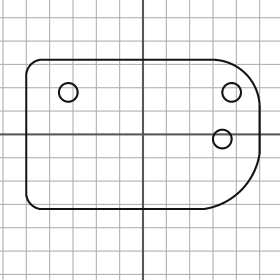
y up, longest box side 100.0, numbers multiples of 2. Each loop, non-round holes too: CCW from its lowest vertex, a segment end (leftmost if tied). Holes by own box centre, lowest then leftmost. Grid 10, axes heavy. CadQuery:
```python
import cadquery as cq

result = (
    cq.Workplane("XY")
    .moveTo(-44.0, -32.0)
    .lineTo(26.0, -32.0)
    .threePointArc((42.0, -24.0), (50.0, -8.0))
    .lineTo(50.0, 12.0)
    .threePointArc((44.0, 26.0), (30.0, 32.0))
    .lineTo(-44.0, 32.0)
    .threePointArc((-48.0, 30.0), (-50.0, 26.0))
    .lineTo(-50.0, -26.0)
    .threePointArc((-48.0, -30.0), (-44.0, -32.0))
    .close()
    .moveTo(34.0, -2.0)
    .circle(4.0)
    .moveTo(-32.0, 18.0)
    .circle(4.0)
    .moveTo(38.0, 18.0)
    .circle(4.0)
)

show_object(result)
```